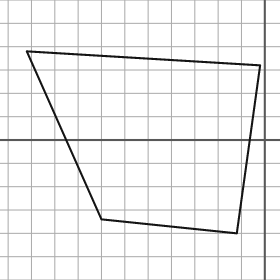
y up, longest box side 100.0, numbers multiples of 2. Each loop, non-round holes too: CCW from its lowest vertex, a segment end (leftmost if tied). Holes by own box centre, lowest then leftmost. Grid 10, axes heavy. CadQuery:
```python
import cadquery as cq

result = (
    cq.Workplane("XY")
    .moveTo(-12.0, -40.0)
    .lineTo(-2.0, 32.0)
    .lineTo(-102.0, 38.0)
    .lineTo(-70.0, -34.0)
    .close()
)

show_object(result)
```